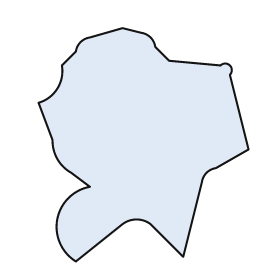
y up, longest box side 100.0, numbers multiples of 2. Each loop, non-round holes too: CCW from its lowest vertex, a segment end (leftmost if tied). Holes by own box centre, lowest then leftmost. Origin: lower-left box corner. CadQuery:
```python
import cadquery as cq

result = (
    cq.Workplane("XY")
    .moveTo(16.0, 0.0)
    .lineTo(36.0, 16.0)
    .threePointArc((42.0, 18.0), (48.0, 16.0))
    .lineTo(62.0, 2.0)
    .lineTo(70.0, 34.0)
    .threePointArc((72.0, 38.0), (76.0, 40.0))
    .lineTo(90.0, 48.0)
    .lineTo(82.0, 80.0)
    .threePointArc((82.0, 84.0), (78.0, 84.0))
    .lineTo(56.0, 86.0)
    .lineTo(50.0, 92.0)
    .threePointArc((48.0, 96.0), (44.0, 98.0))
    .lineTo(36.0, 100.0)
    .lineTo(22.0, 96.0)
    .threePointArc((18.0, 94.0), (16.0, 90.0))
    .lineTo(10.0, 84.0)
    .threePointArc((8.0, 74.0), (0.0, 68.0))
    .lineTo(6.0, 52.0)
    .threePointArc((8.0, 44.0), (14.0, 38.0))
    .lineTo(22.0, 32.0)
    .threePointArc((8.0, 18.0), (16.0, 0.0))
    .close()
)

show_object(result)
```